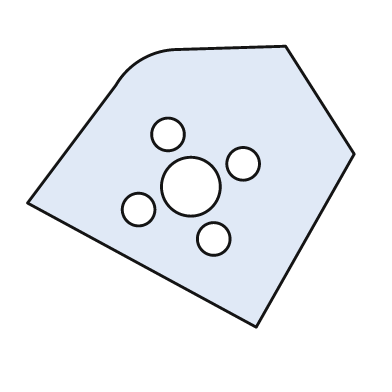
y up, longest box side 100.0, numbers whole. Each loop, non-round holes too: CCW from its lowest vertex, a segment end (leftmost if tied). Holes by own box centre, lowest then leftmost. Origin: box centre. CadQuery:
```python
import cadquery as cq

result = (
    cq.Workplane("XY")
    .moveTo(20.0, -43.0)
    .lineTo(50.0, 10.0)
    .lineTo(29.0, 43.0)
    .lineTo(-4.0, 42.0)
    .threePointArc((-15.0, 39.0), (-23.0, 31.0))
    .lineTo(-50.0, -5.0)
    .close()
    .moveTo(7.0, -16.0)
    .circle(5.0)
    .moveTo(-16.0, -7.0)
    .circle(5.0)
    .moveTo(0.0, 0.0)
    .circle(9.0)
    .moveTo(16.0, 7.0)
    .circle(5.0)
    .moveTo(-7.0, 16.0)
    .circle(5.0)
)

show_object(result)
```